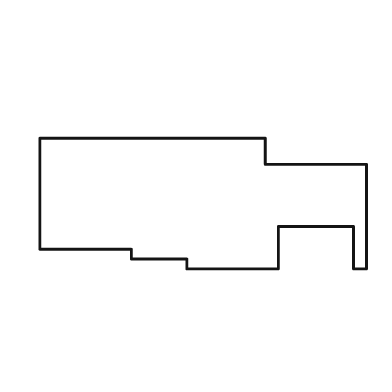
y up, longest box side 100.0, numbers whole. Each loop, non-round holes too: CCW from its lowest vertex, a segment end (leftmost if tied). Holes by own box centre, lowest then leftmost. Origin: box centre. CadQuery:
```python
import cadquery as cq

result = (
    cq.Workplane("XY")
    .moveTo(-5.0, -20.0)
    .lineTo(23.0, -20.0)
    .lineTo(23.0, -7.0)
    .lineTo(46.0, -7.0)
    .lineTo(46.0, -20.0)
    .lineTo(50.0, -20.0)
    .lineTo(50.0, 12.0)
    .lineTo(19.0, 12.0)
    .lineTo(19.0, 20.0)
    .lineTo(-50.0, 20.0)
    .lineTo(-50.0, -14.0)
    .lineTo(-22.0, -14.0)
    .lineTo(-22.0, -17.0)
    .lineTo(-5.0, -17.0)
    .close()
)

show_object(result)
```